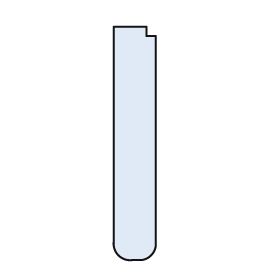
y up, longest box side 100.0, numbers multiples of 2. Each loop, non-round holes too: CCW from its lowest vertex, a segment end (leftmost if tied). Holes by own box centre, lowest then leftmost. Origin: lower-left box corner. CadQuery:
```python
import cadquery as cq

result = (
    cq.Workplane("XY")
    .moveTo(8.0, 0.0)
    .lineTo(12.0, 0.0)
    .threePointArc((16.0, 2.0), (18.0, 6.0))
    .lineTo(18.0, 96.0)
    .lineTo(14.0, 96.0)
    .lineTo(14.0, 100.0)
    .lineTo(0.0, 100.0)
    .lineTo(0.0, 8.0)
    .threePointArc((2.0, 2.0), (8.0, 0.0))
    .close()
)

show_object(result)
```